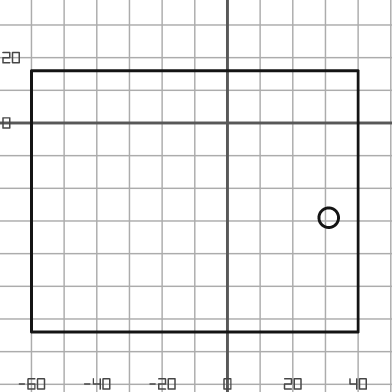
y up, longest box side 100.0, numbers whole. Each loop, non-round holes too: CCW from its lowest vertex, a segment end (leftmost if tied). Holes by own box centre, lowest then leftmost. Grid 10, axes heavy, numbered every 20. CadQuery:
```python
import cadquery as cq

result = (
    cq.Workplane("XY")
    .moveTo(-60.0, -64.0)
    .lineTo(40.0, -64.0)
    .lineTo(40.0, 16.0)
    .lineTo(-60.0, 16.0)
    .close()
    .moveTo(31.0, -29.0)
    .circle(3.0)
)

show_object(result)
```